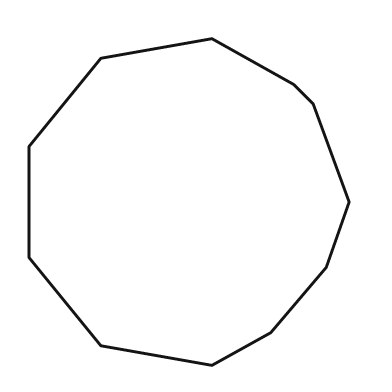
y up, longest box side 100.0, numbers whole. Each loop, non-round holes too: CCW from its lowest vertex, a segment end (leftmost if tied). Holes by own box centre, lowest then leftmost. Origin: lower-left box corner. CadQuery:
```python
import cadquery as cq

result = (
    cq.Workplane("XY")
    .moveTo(56.0, 0.0)
    .lineTo(74.0, 10.0)
    .lineTo(91.0, 30.0)
    .lineTo(98.0, 50.0)
    .lineTo(87.0, 80.0)
    .lineTo(81.0, 86.0)
    .lineTo(56.0, 100.0)
    .lineTo(22.0, 94.0)
    .lineTo(0.0, 67.0)
    .lineTo(0.0, 33.0)
    .lineTo(22.0, 6.0)
    .close()
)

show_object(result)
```